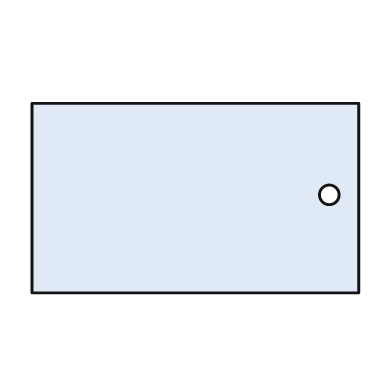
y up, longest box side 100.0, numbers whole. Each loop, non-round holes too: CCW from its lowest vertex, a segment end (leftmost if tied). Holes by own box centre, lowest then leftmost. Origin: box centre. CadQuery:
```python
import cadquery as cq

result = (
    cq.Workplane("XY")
    .moveTo(-50.0, -29.0)
    .lineTo(50.0, -29.0)
    .lineTo(50.0, 29.0)
    .lineTo(-50.0, 29.0)
    .close()
    .moveTo(41.0, 1.0)
    .circle(3.0)
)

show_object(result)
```